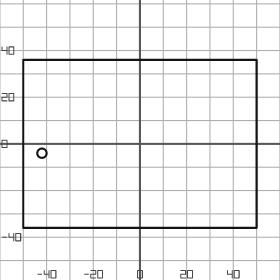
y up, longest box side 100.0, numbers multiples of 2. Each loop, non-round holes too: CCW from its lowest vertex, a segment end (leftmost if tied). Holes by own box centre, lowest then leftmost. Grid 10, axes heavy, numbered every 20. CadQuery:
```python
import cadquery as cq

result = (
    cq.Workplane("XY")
    .moveTo(-50.0, -36.0)
    .lineTo(50.0, -36.0)
    .lineTo(50.0, 36.0)
    .lineTo(-50.0, 36.0)
    .close()
    .moveTo(-42.0, -4.0)
    .circle(2.0)
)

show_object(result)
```